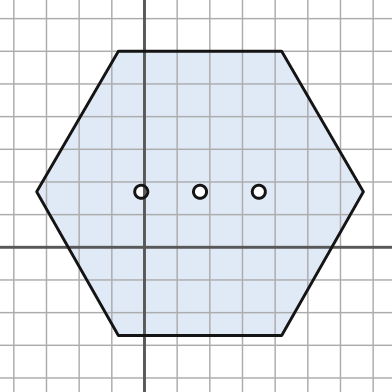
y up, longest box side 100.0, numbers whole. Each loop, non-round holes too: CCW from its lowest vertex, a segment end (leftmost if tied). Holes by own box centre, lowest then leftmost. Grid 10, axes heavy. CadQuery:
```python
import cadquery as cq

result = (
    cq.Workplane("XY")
    .moveTo(-8.0, -27.0)
    .lineTo(42.0, -27.0)
    .lineTo(67.0, 17.0)
    .lineTo(42.0, 60.0)
    .lineTo(-8.0, 60.0)
    .lineTo(-33.0, 17.0)
    .close()
    .moveTo(-1.0, 17.0)
    .circle(2.0)
    .moveTo(17.0, 17.0)
    .circle(2.0)
    .moveTo(35.0, 17.0)
    .circle(2.0)
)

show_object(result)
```